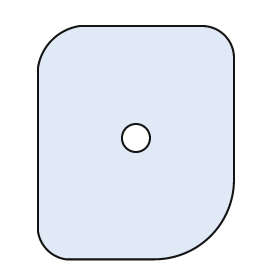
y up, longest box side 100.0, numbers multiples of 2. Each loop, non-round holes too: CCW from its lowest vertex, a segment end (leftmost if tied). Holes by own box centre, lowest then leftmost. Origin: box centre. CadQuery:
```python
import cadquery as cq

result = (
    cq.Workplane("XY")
    .moveTo(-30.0, -50.0)
    .lineTo(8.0, -50.0)
    .threePointArc((32.0, -40.0), (42.0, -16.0))
    .lineTo(42.0, 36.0)
    .threePointArc((38.0, 46.0), (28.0, 50.0))
    .lineTo(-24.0, 50.0)
    .threePointArc((-36.0, 44.0), (-42.0, 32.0))
    .lineTo(-42.0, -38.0)
    .threePointArc((-38.0, -46.0), (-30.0, -50.0))
    .close()
    .moveTo(0.0, 2.0)
    .circle(6.0)
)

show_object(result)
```